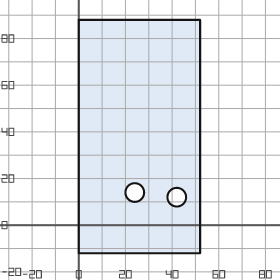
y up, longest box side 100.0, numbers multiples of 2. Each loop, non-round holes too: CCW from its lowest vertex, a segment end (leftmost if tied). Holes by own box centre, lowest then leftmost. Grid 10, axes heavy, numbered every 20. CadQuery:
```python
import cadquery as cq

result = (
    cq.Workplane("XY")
    .moveTo(0.0, -12.0)
    .lineTo(52.0, -12.0)
    .lineTo(52.0, 88.0)
    .lineTo(0.0, 88.0)
    .close()
    .moveTo(42.0, 12.0)
    .circle(4.0)
    .moveTo(24.0, 14.0)
    .circle(4.0)
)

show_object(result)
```